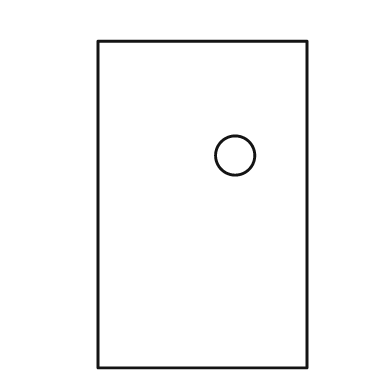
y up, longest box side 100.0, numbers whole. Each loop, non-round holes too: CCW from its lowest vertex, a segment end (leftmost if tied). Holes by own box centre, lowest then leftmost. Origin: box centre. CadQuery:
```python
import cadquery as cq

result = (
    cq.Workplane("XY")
    .moveTo(-32.0, -50.0)
    .lineTo(32.0, -50.0)
    .lineTo(32.0, 50.0)
    .lineTo(-32.0, 50.0)
    .close()
    .moveTo(10.0, 15.0)
    .circle(6.0)
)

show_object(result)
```